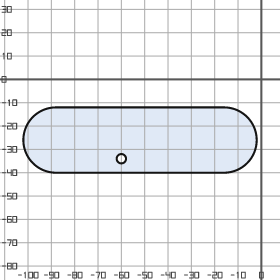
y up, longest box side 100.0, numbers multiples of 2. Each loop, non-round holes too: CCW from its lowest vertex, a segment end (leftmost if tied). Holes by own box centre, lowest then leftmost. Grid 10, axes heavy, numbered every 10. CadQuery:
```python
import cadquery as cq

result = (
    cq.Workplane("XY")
    .moveTo(-88.0, -40.0)
    .lineTo(-16.0, -40.0)
    .threePointArc((-2.0, -26.0), (-16.0, -12.0))
    .lineTo(-88.0, -12.0)
    .threePointArc((-102.0, -26.0), (-88.0, -40.0))
    .close()
    .moveTo(-60.0, -34.0)
    .circle(2.0)
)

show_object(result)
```